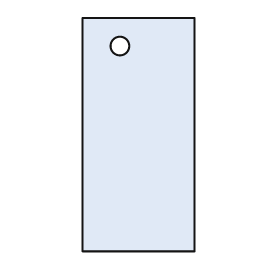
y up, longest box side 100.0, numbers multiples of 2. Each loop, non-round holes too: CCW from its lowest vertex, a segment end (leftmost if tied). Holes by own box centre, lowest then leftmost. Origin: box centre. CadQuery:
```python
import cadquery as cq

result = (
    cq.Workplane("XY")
    .moveTo(-24.0, -50.0)
    .lineTo(24.0, -50.0)
    .lineTo(24.0, 50.0)
    .lineTo(-24.0, 50.0)
    .close()
    .moveTo(-8.0, 38.0)
    .circle(4.0)
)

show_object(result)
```